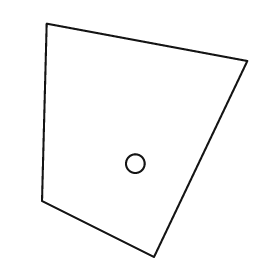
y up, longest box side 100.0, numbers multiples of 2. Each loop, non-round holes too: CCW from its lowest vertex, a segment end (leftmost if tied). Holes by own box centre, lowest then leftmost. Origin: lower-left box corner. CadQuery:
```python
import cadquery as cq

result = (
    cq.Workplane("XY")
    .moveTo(48.0, 0.0)
    .lineTo(88.0, 84.0)
    .lineTo(2.0, 100.0)
    .lineTo(0.0, 24.0)
    .close()
    .moveTo(40.0, 40.0)
    .circle(4.0)
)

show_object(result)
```